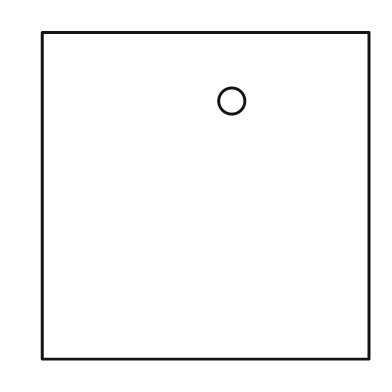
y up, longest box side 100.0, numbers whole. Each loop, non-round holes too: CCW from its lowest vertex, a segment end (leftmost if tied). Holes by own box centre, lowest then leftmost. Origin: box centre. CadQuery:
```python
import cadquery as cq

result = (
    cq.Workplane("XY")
    .moveTo(-50.0, -50.0)
    .lineTo(50.0, -50.0)
    .lineTo(50.0, 50.0)
    .lineTo(-50.0, 50.0)
    .close()
    .moveTo(8.0, 29.0)
    .circle(4.0)
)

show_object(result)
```